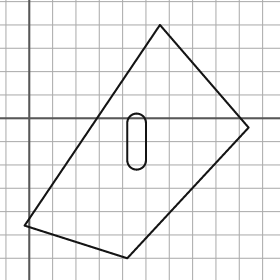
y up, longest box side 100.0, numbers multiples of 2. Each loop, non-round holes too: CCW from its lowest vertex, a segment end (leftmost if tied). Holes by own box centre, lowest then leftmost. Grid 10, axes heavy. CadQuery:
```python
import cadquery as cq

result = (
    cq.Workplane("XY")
    .moveTo(42.0, -60.0)
    .lineTo(94.0, -4.0)
    .lineTo(56.0, 40.0)
    .lineTo(-2.0, -46.0)
    .close()
    .moveTo(42.0, -18.0)
    .threePointArc((46.0, -22.0), (50.0, -18.0))
    .lineTo(50.0, -2.0)
    .threePointArc((46.0, 2.0), (42.0, -2.0))
    .close()
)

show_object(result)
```